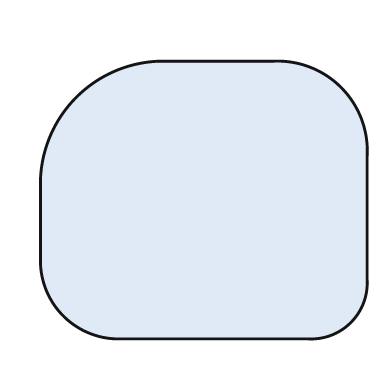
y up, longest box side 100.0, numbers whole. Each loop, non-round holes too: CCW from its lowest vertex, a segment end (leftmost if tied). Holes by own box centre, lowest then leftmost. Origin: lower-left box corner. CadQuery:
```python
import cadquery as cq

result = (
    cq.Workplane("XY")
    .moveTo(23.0, 0.0)
    .lineTo(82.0, 0.0)
    .threePointArc((95.0, 5.0), (100.0, 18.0))
    .lineTo(100.0, 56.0)
    .threePointArc((92.0, 77.0), (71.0, 85.0))
    .lineTo(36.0, 85.0)
    .threePointArc((11.0, 74.0), (0.0, 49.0))
    .lineTo(0.0, 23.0)
    .threePointArc((7.0, 7.0), (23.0, 0.0))
    .close()
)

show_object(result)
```